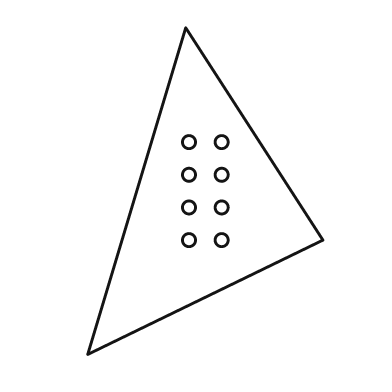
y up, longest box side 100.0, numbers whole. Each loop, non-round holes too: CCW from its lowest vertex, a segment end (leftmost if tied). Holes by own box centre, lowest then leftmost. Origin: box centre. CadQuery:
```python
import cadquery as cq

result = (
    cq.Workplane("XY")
    .moveTo(-36.0, -50.0)
    .lineTo(36.0, -15.0)
    .lineTo(-6.0, 50.0)
    .close()
    .moveTo(-5.0, -15.0)
    .circle(2.0)
    .moveTo(5.0, -15.0)
    .circle(2.0)
    .moveTo(-5.0, -5.0)
    .circle(2.0)
    .moveTo(5.0, -5.0)
    .circle(2.0)
    .moveTo(-5.0, 5.0)
    .circle(2.0)
    .moveTo(5.0, 5.0)
    .circle(2.0)
    .moveTo(-5.0, 15.0)
    .circle(2.0)
    .moveTo(5.0, 15.0)
    .circle(2.0)
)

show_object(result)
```